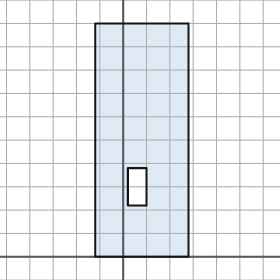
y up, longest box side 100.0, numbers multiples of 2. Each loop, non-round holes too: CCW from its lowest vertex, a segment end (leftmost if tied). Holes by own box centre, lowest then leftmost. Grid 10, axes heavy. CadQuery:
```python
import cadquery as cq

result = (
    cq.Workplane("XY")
    .moveTo(-12.0, 0.0)
    .lineTo(28.0, 0.0)
    .lineTo(28.0, 100.0)
    .lineTo(-12.0, 100.0)
    .close()
    .moveTo(2.0, 22.0)
    .lineTo(10.0, 22.0)
    .lineTo(10.0, 38.0)
    .lineTo(2.0, 38.0)
    .close()
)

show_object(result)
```